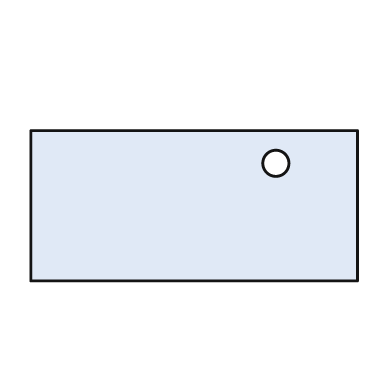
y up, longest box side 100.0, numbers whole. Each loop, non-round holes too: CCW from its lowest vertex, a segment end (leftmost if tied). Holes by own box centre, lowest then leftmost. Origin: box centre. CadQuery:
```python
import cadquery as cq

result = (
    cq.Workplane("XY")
    .moveTo(-50.0, -23.0)
    .lineTo(50.0, -23.0)
    .lineTo(50.0, 23.0)
    .lineTo(-50.0, 23.0)
    .close()
    .moveTo(25.0, 13.0)
    .circle(4.0)
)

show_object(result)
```